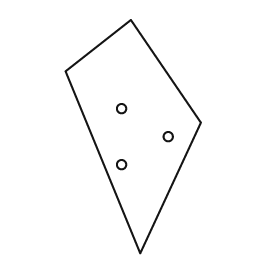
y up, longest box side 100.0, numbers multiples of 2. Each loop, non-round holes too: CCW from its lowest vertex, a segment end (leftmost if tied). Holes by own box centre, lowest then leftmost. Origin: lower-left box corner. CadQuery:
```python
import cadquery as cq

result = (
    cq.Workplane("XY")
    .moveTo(32.0, 0.0)
    .lineTo(58.0, 56.0)
    .lineTo(28.0, 100.0)
    .lineTo(0.0, 78.0)
    .close()
    .moveTo(24.0, 38.0)
    .circle(2.0)
    .moveTo(44.0, 50.0)
    .circle(2.0)
    .moveTo(24.0, 62.0)
    .circle(2.0)
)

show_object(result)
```